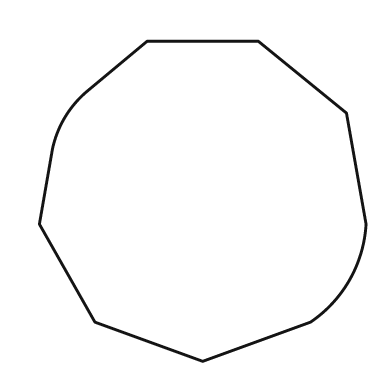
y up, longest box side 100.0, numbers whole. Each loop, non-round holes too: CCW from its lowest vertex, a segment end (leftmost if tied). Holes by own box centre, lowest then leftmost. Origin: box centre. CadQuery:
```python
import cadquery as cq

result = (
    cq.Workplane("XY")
    .moveTo(0.0, -49.0)
    .lineTo(33.0, -37.0)
    .threePointArc((45.0, -24.0), (50.0, -7.0))
    .lineTo(44.0, 27.0)
    .lineTo(17.0, 49.0)
    .lineTo(-17.0, 49.0)
    .lineTo(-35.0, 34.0)
    .threePointArc((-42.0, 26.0), (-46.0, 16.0))
    .lineTo(-50.0, -7.0)
    .lineTo(-33.0, -37.0)
    .close()
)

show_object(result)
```